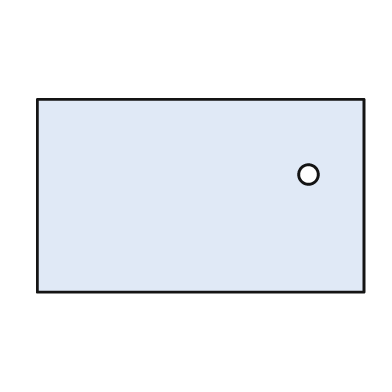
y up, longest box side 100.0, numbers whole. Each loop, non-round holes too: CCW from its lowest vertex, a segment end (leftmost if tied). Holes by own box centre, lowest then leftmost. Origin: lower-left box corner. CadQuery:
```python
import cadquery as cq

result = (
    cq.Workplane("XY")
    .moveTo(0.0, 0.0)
    .lineTo(100.0, 0.0)
    .lineTo(100.0, 59.0)
    .lineTo(0.0, 59.0)
    .close()
    .moveTo(83.0, 36.0)
    .circle(3.0)
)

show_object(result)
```